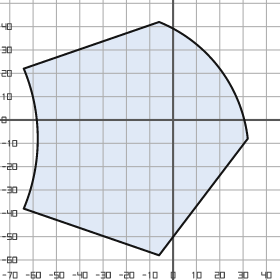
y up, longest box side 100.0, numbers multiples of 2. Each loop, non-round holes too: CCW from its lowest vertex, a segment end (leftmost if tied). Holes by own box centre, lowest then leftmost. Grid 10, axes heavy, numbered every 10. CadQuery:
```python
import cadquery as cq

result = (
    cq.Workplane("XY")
    .moveTo(-6.0, -58.0)
    .lineTo(32.0, -8.0)
    .threePointArc((20.0, 22.0), (-6.0, 42.0))
    .lineTo(-64.0, 22.0)
    .threePointArc((-58.0, -8.0), (-64.0, -38.0))
    .close()
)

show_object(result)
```